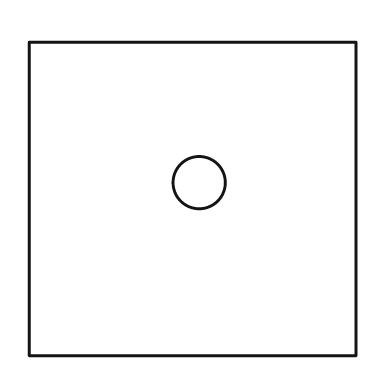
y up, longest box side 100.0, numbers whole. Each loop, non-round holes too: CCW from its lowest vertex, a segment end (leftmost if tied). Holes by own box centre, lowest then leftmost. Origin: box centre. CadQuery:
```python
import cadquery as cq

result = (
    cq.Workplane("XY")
    .moveTo(-50.0, -48.0)
    .lineTo(50.0, -48.0)
    .lineTo(50.0, 48.0)
    .lineTo(-50.0, 48.0)
    .close()
    .moveTo(2.0, 5.0)
    .circle(8.0)
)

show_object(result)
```